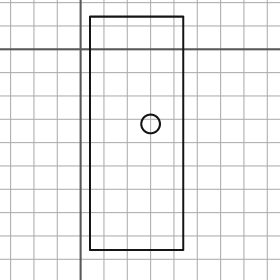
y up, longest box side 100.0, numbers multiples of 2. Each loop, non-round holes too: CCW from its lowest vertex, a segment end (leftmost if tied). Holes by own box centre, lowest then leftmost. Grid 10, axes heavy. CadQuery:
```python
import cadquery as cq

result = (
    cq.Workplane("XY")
    .moveTo(4.0, -86.0)
    .lineTo(44.0, -86.0)
    .lineTo(44.0, 14.0)
    .lineTo(4.0, 14.0)
    .close()
    .moveTo(30.0, -32.0)
    .circle(4.0)
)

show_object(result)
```